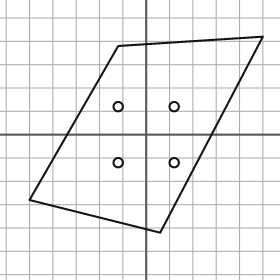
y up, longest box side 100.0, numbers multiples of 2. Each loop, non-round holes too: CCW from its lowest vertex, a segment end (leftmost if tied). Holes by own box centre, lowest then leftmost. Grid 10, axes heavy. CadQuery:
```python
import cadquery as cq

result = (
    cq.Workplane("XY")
    .moveTo(6.0, -42.0)
    .lineTo(50.0, 42.0)
    .lineTo(-12.0, 38.0)
    .lineTo(-50.0, -28.0)
    .close()
    .moveTo(-12.0, -12.0)
    .circle(2.0)
    .moveTo(12.0, -12.0)
    .circle(2.0)
    .moveTo(-12.0, 12.0)
    .circle(2.0)
    .moveTo(12.0, 12.0)
    .circle(2.0)
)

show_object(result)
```